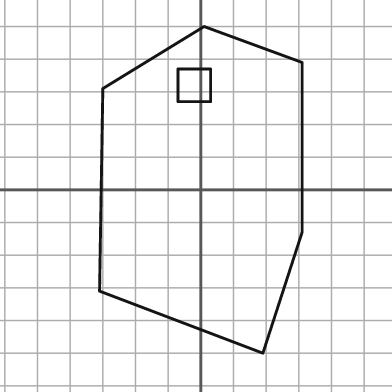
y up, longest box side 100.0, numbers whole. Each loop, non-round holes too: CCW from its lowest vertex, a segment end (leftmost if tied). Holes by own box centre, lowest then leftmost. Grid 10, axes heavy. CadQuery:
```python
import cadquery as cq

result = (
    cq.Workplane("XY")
    .moveTo(19.0, -50.0)
    .lineTo(31.0, -13.0)
    .lineTo(31.0, 39.0)
    .lineTo(1.0, 50.0)
    .lineTo(-30.0, 31.0)
    .lineTo(-31.0, -31.0)
    .close()
    .moveTo(-7.0, 27.0)
    .lineTo(3.0, 27.0)
    .lineTo(3.0, 37.0)
    .lineTo(-7.0, 37.0)
    .close()
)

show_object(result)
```